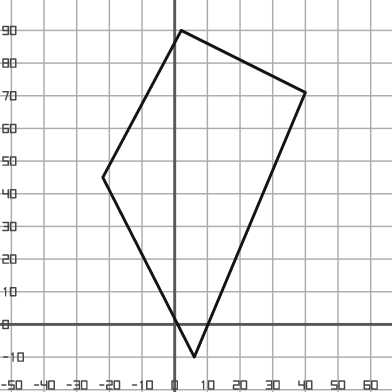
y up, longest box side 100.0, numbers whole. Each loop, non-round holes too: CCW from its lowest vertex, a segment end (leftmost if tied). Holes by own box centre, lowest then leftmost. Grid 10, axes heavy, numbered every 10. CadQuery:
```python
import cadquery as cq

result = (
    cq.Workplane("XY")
    .moveTo(6.0, -10.0)
    .lineTo(40.0, 71.0)
    .lineTo(2.0, 90.0)
    .lineTo(-22.0, 45.0)
    .close()
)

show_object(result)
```